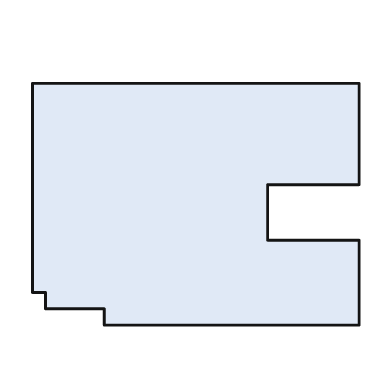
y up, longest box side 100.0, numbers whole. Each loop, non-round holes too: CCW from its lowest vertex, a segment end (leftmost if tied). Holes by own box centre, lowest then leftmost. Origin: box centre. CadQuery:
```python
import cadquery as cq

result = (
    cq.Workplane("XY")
    .moveTo(-28.0, -37.0)
    .lineTo(50.0, -37.0)
    .lineTo(50.0, -11.0)
    .lineTo(22.0, -11.0)
    .lineTo(22.0, 6.0)
    .lineTo(50.0, 6.0)
    .lineTo(50.0, 37.0)
    .lineTo(-50.0, 37.0)
    .lineTo(-50.0, -27.0)
    .lineTo(-46.0, -27.0)
    .lineTo(-46.0, -32.0)
    .lineTo(-28.0, -32.0)
    .close()
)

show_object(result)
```